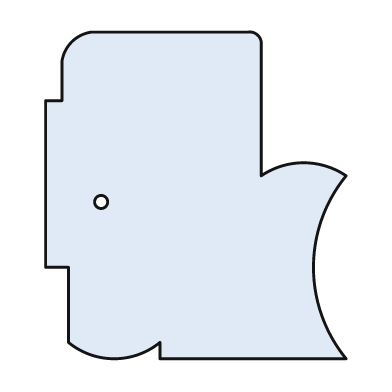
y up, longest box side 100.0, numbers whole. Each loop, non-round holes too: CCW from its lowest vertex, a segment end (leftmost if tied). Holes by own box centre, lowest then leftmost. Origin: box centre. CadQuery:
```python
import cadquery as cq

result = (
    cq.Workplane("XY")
    .moveTo(-11.0, -50.0)
    .lineTo(46.0, -50.0)
    .threePointArc((36.0, -22.0), (46.0, 6.0))
    .threePointArc((33.0, 10.0), (20.0, 6.0))
    .lineTo(20.0, 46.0)
    .threePointArc((19.0, 49.0), (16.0, 50.0))
    .lineTo(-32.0, 50.0)
    .threePointArc((-38.0, 47.0), (-41.0, 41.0))
    .lineTo(-41.0, 29.0)
    .lineTo(-46.0, 29.0)
    .lineTo(-46.0, -22.0)
    .lineTo(-39.0, -22.0)
    .lineTo(-39.0, -45.0)
    .threePointArc((-25.0, -50.0), (-11.0, -45.0))
    .close()
    .moveTo(-29.0, -2.0)
    .circle(2.0)
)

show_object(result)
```